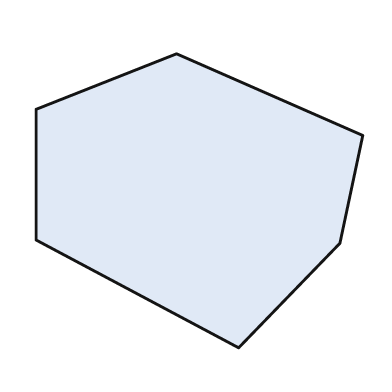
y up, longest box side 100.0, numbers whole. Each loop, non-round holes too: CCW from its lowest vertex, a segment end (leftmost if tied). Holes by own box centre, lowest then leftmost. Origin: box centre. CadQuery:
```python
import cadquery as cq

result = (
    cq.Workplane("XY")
    .moveTo(12.0, -45.0)
    .lineTo(43.0, -13.0)
    .lineTo(50.0, 20.0)
    .lineTo(-7.0, 45.0)
    .lineTo(-50.0, 28.0)
    .lineTo(-50.0, -12.0)
    .close()
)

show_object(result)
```